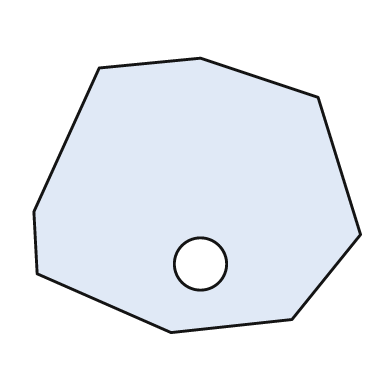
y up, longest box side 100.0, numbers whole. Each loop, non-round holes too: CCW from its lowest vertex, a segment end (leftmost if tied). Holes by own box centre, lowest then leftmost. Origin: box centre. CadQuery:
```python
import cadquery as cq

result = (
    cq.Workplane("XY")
    .moveTo(-8.0, -42.0)
    .lineTo(29.0, -38.0)
    .lineTo(50.0, -12.0)
    .lineTo(37.0, 30.0)
    .lineTo(1.0, 42.0)
    .lineTo(-30.0, 39.0)
    .lineTo(-50.0, -5.0)
    .lineTo(-49.0, -24.0)
    .close()
    .moveTo(1.0, -21.0)
    .circle(8.0)
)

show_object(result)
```